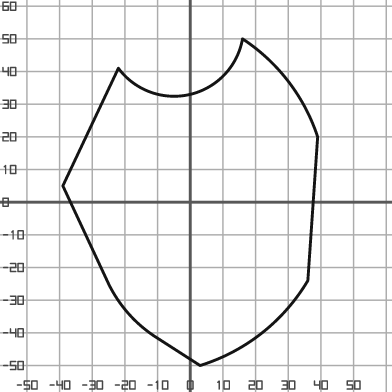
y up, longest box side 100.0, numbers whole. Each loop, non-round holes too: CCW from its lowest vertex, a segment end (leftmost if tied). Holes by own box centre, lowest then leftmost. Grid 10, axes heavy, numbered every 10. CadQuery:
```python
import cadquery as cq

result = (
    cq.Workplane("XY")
    .moveTo(3.0, -50.0)
    .threePointArc((22.0, -40.0), (36.0, -24.0))
    .lineTo(39.0, 20.0)
    .threePointArc((30.0, 37.0), (16.0, 50.0))
    .threePointArc((0.0, 33.0), (-22.0, 41.0))
    .lineTo(-39.0, 5.0)
    .lineTo(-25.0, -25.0)
    .threePointArc((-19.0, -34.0), (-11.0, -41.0))
    .close()
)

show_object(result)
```